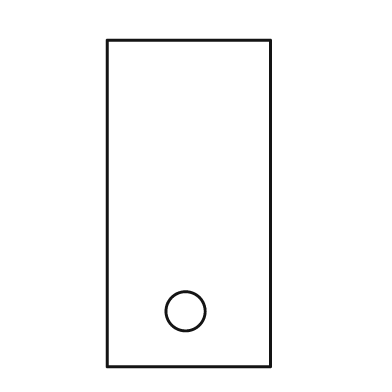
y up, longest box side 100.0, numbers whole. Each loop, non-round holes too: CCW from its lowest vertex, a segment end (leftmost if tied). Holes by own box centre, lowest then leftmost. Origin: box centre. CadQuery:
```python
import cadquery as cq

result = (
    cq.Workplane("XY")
    .moveTo(-25.0, -50.0)
    .lineTo(25.0, -50.0)
    .lineTo(25.0, 50.0)
    .lineTo(-25.0, 50.0)
    .close()
    .moveTo(-1.0, -33.0)
    .circle(6.0)
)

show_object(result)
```